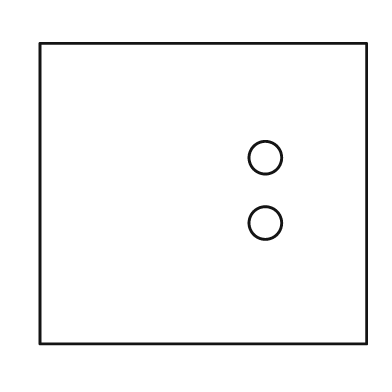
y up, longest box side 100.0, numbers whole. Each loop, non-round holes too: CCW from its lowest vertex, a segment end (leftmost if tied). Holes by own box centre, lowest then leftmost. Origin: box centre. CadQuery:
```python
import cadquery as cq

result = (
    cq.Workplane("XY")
    .moveTo(-50.0, -46.0)
    .lineTo(50.0, -46.0)
    .lineTo(50.0, 46.0)
    .lineTo(-50.0, 46.0)
    .close()
    .moveTo(19.0, -9.0)
    .circle(5.0)
    .moveTo(19.0, 11.0)
    .circle(5.0)
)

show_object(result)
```